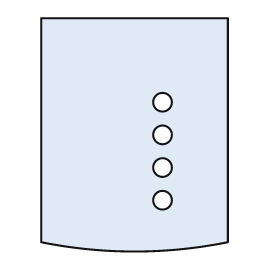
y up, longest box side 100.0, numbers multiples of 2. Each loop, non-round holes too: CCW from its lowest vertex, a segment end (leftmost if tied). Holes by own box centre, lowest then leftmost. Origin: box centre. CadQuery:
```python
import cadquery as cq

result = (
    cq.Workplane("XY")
    .moveTo(-40.0, -46.0)
    .threePointArc((0.0, -50.0), (40.0, -46.0))
    .lineTo(40.0, 50.0)
    .lineTo(-40.0, 50.0)
    .close()
    .moveTo(12.0, -28.0)
    .circle(4.0)
    .moveTo(12.0, -14.0)
    .circle(4.0)
    .moveTo(12.0, 0.0)
    .circle(4.0)
    .moveTo(12.0, 14.0)
    .circle(4.0)
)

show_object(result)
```